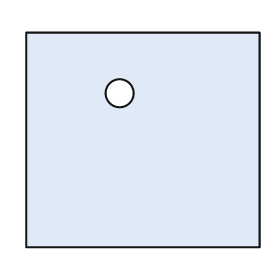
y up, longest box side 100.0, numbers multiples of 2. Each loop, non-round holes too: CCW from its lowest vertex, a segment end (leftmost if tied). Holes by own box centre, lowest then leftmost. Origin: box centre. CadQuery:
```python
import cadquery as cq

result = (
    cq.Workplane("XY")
    .moveTo(-50.0, -46.0)
    .lineTo(50.0, -46.0)
    .lineTo(50.0, 46.0)
    .lineTo(-50.0, 46.0)
    .close()
    .moveTo(-10.0, 20.0)
    .circle(6.0)
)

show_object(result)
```